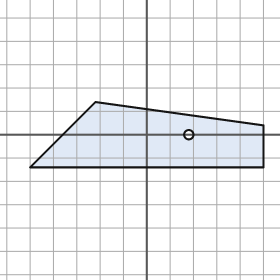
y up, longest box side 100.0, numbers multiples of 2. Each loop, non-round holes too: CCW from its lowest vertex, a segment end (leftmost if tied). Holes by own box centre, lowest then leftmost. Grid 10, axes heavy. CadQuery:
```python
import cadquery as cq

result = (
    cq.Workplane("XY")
    .moveTo(-50.0, -14.0)
    .lineTo(50.0, -14.0)
    .lineTo(50.0, 4.0)
    .lineTo(-22.0, 14.0)
    .close()
    .moveTo(18.0, 0.0)
    .circle(2.0)
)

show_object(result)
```